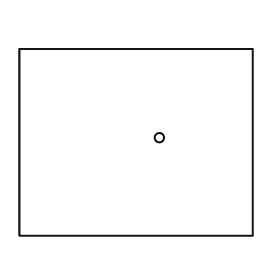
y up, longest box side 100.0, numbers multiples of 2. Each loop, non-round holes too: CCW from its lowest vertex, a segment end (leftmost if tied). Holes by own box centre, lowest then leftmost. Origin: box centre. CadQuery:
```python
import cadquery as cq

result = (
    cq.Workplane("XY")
    .moveTo(-50.0, -40.0)
    .lineTo(50.0, -40.0)
    .lineTo(50.0, 40.0)
    .lineTo(-50.0, 40.0)
    .close()
    .moveTo(10.0, 2.0)
    .circle(2.0)
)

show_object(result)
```